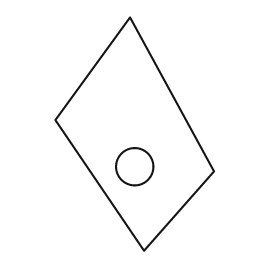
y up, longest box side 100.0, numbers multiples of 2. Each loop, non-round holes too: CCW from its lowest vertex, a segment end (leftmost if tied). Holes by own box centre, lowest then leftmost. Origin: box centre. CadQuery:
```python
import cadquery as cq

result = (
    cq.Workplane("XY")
    .moveTo(4.0, -50.0)
    .lineTo(34.0, -16.0)
    .lineTo(-2.0, 50.0)
    .lineTo(-34.0, 6.0)
    .close()
    .moveTo(0.0, -14.0)
    .circle(8.0)
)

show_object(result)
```